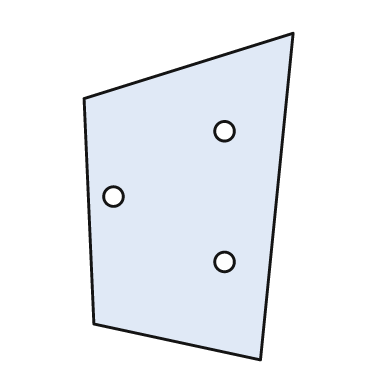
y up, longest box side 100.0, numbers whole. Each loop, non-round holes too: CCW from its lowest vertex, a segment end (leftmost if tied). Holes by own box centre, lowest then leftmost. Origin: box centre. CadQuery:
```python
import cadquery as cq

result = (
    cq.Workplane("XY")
    .moveTo(22.0, -50.0)
    .lineTo(32.0, 50.0)
    .lineTo(-32.0, 30.0)
    .lineTo(-29.0, -39.0)
    .close()
    .moveTo(11.0, -20.0)
    .circle(3.0)
    .moveTo(-23.0, 0.0)
    .circle(3.0)
    .moveTo(11.0, 20.0)
    .circle(3.0)
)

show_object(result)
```